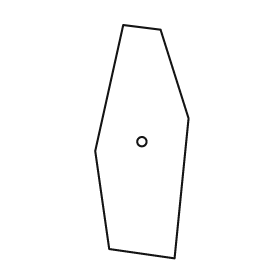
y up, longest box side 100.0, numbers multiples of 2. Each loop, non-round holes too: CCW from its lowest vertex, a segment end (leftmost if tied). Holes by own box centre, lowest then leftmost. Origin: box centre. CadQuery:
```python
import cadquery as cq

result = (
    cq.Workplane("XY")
    .moveTo(14.0, -50.0)
    .lineTo(20.0, 10.0)
    .lineTo(8.0, 48.0)
    .lineTo(-8.0, 50.0)
    .lineTo(-20.0, -4.0)
    .lineTo(-14.0, -46.0)
    .close()
    .moveTo(0.0, 0.0)
    .circle(2.0)
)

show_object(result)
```